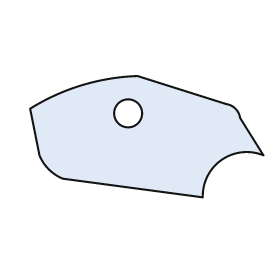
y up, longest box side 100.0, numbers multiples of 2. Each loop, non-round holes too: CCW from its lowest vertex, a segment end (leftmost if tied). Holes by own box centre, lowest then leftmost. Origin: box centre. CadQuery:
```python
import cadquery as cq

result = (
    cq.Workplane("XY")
    .moveTo(24.0, -26.0)
    .threePointArc((32.0, -10.0), (50.0, -8.0))
    .lineTo(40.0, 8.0)
    .threePointArc((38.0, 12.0), (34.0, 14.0))
    .lineTo(-4.0, 26.0)
    .threePointArc((-28.0, 22.0), (-50.0, 12.0))
    .lineTo(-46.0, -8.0)
    .threePointArc((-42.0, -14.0), (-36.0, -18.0))
    .close()
    .moveTo(-8.0, 10.0)
    .circle(6.0)
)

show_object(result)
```